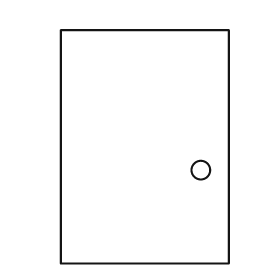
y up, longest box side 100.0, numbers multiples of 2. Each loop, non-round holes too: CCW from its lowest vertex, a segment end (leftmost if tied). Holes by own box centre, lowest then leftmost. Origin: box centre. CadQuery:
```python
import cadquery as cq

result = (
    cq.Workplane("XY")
    .moveTo(-36.0, -50.0)
    .lineTo(36.0, -50.0)
    .lineTo(36.0, 50.0)
    .lineTo(-36.0, 50.0)
    .close()
    .moveTo(24.0, -10.0)
    .circle(4.0)
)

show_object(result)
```